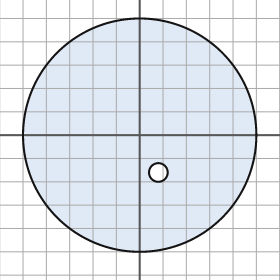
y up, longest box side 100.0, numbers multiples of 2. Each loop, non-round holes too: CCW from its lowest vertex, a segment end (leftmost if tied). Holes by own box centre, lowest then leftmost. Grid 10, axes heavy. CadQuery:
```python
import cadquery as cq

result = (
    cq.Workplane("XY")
    .moveTo(0.0, 0.0)
    .circle(50.0)
    .moveTo(8.0, -16.0)
    .circle(4.0)
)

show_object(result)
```